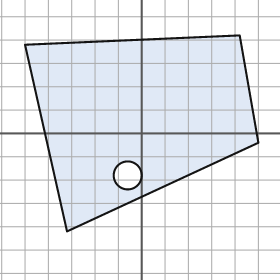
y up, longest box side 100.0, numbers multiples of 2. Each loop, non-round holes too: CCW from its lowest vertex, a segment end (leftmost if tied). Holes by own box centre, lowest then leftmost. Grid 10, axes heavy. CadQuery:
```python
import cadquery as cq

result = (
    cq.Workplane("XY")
    .moveTo(-32.0, -42.0)
    .lineTo(50.0, -4.0)
    .lineTo(42.0, 42.0)
    .lineTo(-50.0, 38.0)
    .close()
    .moveTo(-6.0, -18.0)
    .circle(6.0)
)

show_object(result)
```